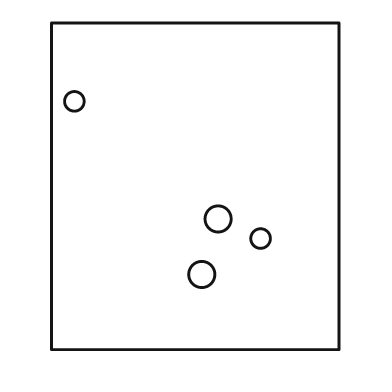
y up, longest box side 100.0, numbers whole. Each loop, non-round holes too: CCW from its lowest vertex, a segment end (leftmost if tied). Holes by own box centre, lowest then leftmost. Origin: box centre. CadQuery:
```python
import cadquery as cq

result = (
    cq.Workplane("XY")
    .moveTo(-44.0, -50.0)
    .lineTo(44.0, -50.0)
    .lineTo(44.0, 50.0)
    .lineTo(-44.0, 50.0)
    .close()
    .moveTo(2.0, -27.0)
    .circle(4.0)
    .moveTo(20.0, -16.0)
    .circle(3.0)
    .moveTo(7.0, -10.0)
    .circle(4.0)
    .moveTo(-37.0, 26.0)
    .circle(3.0)
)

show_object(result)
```